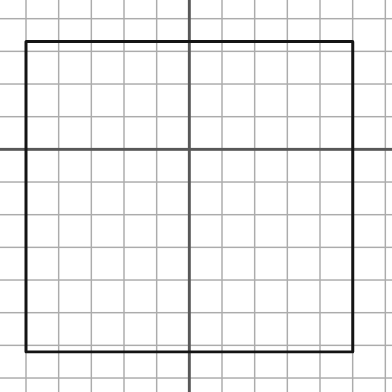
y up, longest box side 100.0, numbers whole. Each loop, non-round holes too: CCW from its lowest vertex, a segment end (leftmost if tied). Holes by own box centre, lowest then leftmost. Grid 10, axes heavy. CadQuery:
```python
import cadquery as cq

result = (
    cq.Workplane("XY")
    .moveTo(-50.0, -62.0)
    .lineTo(50.0, -62.0)
    .lineTo(50.0, 33.0)
    .lineTo(-50.0, 33.0)
    .close()
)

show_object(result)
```